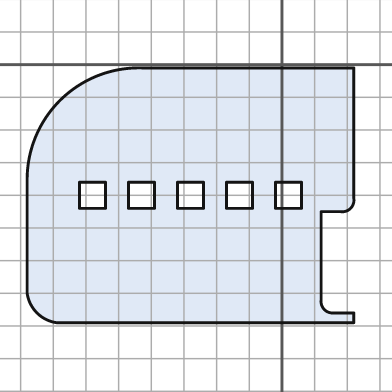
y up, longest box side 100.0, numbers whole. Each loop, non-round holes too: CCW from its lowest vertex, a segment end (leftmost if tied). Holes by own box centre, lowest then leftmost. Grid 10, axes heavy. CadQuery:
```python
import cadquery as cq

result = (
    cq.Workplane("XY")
    .moveTo(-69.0, -79.0)
    .lineTo(22.0, -79.0)
    .lineTo(22.0, -76.0)
    .lineTo(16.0, -76.0)
    .threePointArc((13.0, -75.0), (12.0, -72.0))
    .lineTo(12.0, -45.0)
    .lineTo(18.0, -45.0)
    .threePointArc((21.0, -44.0), (22.0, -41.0))
    .lineTo(22.0, -1.0)
    .lineTo(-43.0, -1.0)
    .threePointArc((-68.0, -11.0), (-78.0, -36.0))
    .lineTo(-78.0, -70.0)
    .threePointArc((-75.0, -76.0), (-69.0, -79.0))
    .close()
    .moveTo(-62.0, -44.0)
    .lineTo(-54.0, -44.0)
    .lineTo(-54.0, -36.0)
    .lineTo(-62.0, -36.0)
    .close()
    .moveTo(-47.0, -44.0)
    .lineTo(-39.0, -44.0)
    .lineTo(-39.0, -36.0)
    .lineTo(-47.0, -36.0)
    .close()
    .moveTo(-32.0, -44.0)
    .lineTo(-24.0, -44.0)
    .lineTo(-24.0, -36.0)
    .lineTo(-32.0, -36.0)
    .close()
    .moveTo(-17.0, -44.0)
    .lineTo(-9.0, -44.0)
    .lineTo(-9.0, -36.0)
    .lineTo(-17.0, -36.0)
    .close()
    .moveTo(-2.0, -44.0)
    .lineTo(6.0, -44.0)
    .lineTo(6.0, -36.0)
    .lineTo(-2.0, -36.0)
    .close()
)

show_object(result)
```